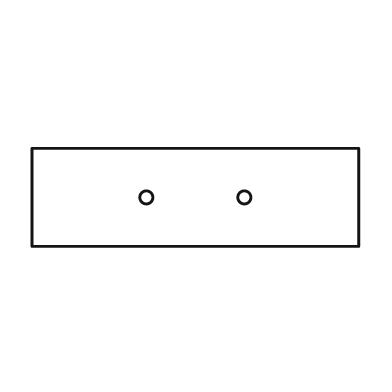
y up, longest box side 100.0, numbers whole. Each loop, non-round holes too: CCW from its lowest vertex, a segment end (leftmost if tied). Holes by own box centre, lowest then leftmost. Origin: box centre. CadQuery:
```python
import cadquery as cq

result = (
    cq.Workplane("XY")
    .moveTo(-50.0, -15.0)
    .lineTo(50.0, -15.0)
    .lineTo(50.0, 15.0)
    .lineTo(-50.0, 15.0)
    .close()
    .moveTo(-15.0, 0.0)
    .circle(2.0)
    .moveTo(15.0, 0.0)
    .circle(2.0)
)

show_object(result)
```